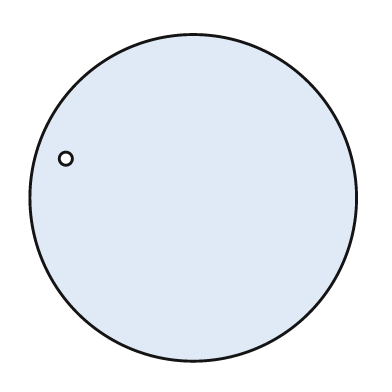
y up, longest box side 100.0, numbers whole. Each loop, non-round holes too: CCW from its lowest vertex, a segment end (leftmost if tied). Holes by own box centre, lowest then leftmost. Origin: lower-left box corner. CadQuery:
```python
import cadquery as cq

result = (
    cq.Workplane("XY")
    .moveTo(50.0, 50.0)
    .circle(50.0)
    .moveTo(11.0, 62.0)
    .circle(2.0)
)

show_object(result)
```